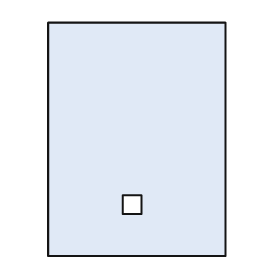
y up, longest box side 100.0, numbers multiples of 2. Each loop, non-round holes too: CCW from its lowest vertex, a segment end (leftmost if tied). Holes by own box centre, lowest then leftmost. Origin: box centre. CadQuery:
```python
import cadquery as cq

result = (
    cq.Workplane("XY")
    .moveTo(-38.0, -50.0)
    .lineTo(38.0, -50.0)
    .lineTo(38.0, 50.0)
    .lineTo(-38.0, 50.0)
    .close()
    .moveTo(-6.0, -32.0)
    .lineTo(2.0, -32.0)
    .lineTo(2.0, -24.0)
    .lineTo(-6.0, -24.0)
    .close()
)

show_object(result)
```